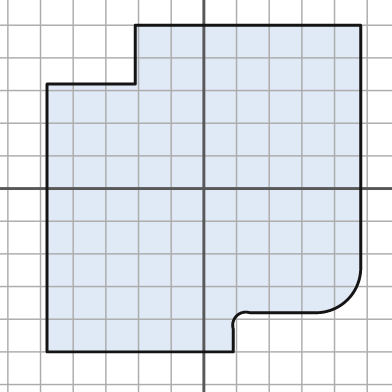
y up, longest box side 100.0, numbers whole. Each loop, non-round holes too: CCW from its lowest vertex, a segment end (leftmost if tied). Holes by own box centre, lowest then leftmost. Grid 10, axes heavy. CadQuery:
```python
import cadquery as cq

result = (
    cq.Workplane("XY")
    .moveTo(-48.0, -50.0)
    .lineTo(9.0, -50.0)
    .lineTo(9.0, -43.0)
    .threePointArc((10.0, -39.0), (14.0, -38.0))
    .lineTo(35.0, -38.0)
    .threePointArc((44.0, -34.0), (48.0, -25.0))
    .lineTo(48.0, 50.0)
    .lineTo(-21.0, 50.0)
    .lineTo(-21.0, 32.0)
    .lineTo(-48.0, 32.0)
    .close()
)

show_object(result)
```